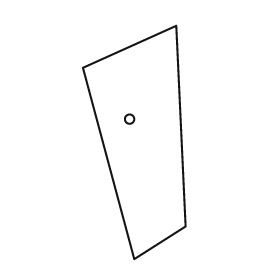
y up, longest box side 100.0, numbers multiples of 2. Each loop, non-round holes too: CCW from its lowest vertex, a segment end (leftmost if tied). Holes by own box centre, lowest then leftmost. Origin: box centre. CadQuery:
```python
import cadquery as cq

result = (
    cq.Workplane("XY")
    .moveTo(0.0, -50.0)
    .lineTo(22.0, -36.0)
    .lineTo(18.0, 50.0)
    .lineTo(-22.0, 32.0)
    .close()
    .moveTo(-2.0, 10.0)
    .circle(2.0)
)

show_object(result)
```